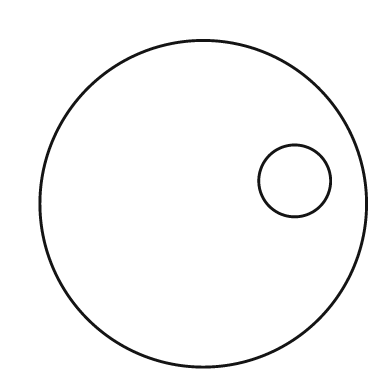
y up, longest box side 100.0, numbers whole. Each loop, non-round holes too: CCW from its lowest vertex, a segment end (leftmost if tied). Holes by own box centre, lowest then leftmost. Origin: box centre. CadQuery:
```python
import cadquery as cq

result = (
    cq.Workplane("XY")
    .moveTo(0.0, 0.0)
    .circle(50.0)
    .moveTo(28.0, 7.0)
    .circle(11.0)
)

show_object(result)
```